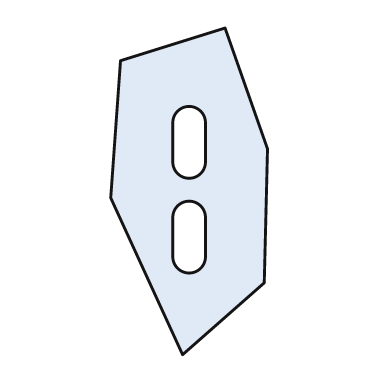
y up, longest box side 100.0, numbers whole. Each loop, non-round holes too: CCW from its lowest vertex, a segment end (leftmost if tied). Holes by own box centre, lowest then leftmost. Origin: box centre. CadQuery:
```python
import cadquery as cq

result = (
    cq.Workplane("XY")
    .moveTo(-2.0, -50.0)
    .lineTo(23.0, -28.0)
    .lineTo(24.0, 13.0)
    .lineTo(11.0, 50.0)
    .lineTo(-21.0, 40.0)
    .lineTo(-24.0, -2.0)
    .close()
    .moveTo(-5.0, -20.0)
    .threePointArc((0.0, -25.0), (5.0, -20.0))
    .lineTo(5.0, -8.0)
    .threePointArc((0.0, -3.0), (-5.0, -8.0))
    .close()
    .moveTo(-5.0, 9.0)
    .threePointArc((0.0, 4.0), (5.0, 9.0))
    .lineTo(5.0, 21.0)
    .threePointArc((0.0, 26.0), (-5.0, 21.0))
    .close()
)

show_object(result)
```